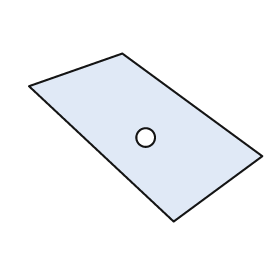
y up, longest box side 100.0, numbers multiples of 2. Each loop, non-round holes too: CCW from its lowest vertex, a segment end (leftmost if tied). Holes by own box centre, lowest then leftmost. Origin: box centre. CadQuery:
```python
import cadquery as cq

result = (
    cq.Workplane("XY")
    .moveTo(12.0, -36.0)
    .lineTo(50.0, -8.0)
    .lineTo(-10.0, 36.0)
    .lineTo(-50.0, 22.0)
    .close()
    .moveTo(0.0, 0.0)
    .circle(4.0)
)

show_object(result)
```